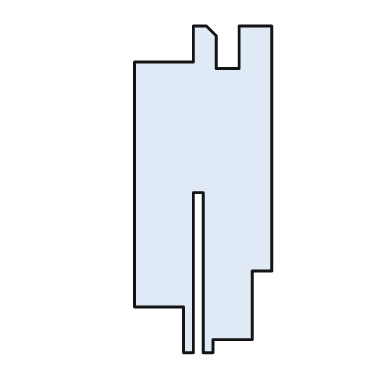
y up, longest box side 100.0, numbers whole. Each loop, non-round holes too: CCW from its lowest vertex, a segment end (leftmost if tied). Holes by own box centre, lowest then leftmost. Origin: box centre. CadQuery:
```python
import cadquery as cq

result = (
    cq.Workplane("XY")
    .moveTo(-6.0, -50.0)
    .lineTo(-3.0, -50.0)
    .lineTo(-3.0, -1.0)
    .lineTo(0.0, -1.0)
    .lineTo(0.0, -50.0)
    .lineTo(3.0, -50.0)
    .lineTo(3.0, -46.0)
    .lineTo(15.0, -46.0)
    .lineTo(15.0, -25.0)
    .lineTo(21.0, -25.0)
    .lineTo(21.0, 50.0)
    .lineTo(11.0, 50.0)
    .lineTo(11.0, 37.0)
    .lineTo(4.0, 37.0)
    .lineTo(4.0, 47.0)
    .lineTo(1.0, 50.0)
    .lineTo(-3.0, 50.0)
    .lineTo(-3.0, 39.0)
    .lineTo(-21.0, 39.0)
    .lineTo(-21.0, -36.0)
    .lineTo(-6.0, -36.0)
    .close()
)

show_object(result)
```